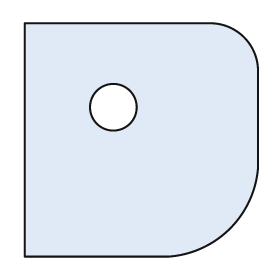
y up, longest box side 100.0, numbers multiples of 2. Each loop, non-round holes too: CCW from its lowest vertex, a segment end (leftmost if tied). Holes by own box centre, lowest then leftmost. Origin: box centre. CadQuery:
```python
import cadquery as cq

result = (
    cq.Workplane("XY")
    .moveTo(-50.0, -50.0)
    .lineTo(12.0, -50.0)
    .threePointArc((38.0, -38.0), (50.0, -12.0))
    .lineTo(50.0, 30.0)
    .threePointArc((44.0, 44.0), (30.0, 50.0))
    .lineTo(-50.0, 50.0)
    .close()
    .moveTo(-12.0, 14.0)
    .circle(10.0)
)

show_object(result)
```